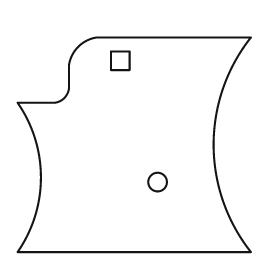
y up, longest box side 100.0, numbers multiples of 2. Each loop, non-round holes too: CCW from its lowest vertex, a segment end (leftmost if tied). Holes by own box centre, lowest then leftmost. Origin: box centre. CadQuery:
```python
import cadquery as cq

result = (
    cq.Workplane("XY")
    .moveTo(-50.0, -46.0)
    .lineTo(50.0, -46.0)
    .threePointArc((34.0, 0.0), (50.0, 46.0))
    .lineTo(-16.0, 46.0)
    .threePointArc((-24.0, 42.0), (-28.0, 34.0))
    .lineTo(-28.0, 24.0)
    .threePointArc((-30.0, 20.0), (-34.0, 18.0))
    .lineTo(-50.0, 18.0)
    .threePointArc((-40.0, -14.0), (-50.0, -46.0))
    .close()
    .moveTo(10.0, -16.0)
    .circle(4.0)
    .moveTo(-10.0, 32.0)
    .lineTo(-2.0, 32.0)
    .lineTo(-2.0, 40.0)
    .lineTo(-10.0, 40.0)
    .close()
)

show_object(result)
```